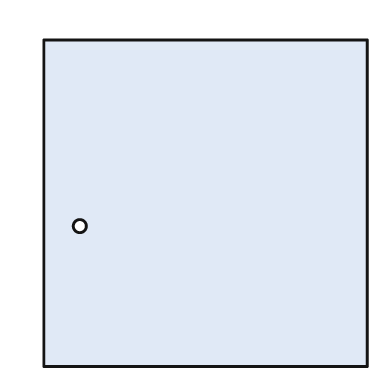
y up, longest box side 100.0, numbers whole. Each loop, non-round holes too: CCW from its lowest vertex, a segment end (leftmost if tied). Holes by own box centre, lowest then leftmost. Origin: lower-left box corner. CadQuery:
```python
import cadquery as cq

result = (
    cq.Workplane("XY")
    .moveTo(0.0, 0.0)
    .lineTo(99.0, 0.0)
    .lineTo(99.0, 100.0)
    .lineTo(0.0, 100.0)
    .close()
    .moveTo(11.0, 43.0)
    .circle(2.0)
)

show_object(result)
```